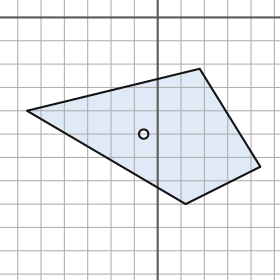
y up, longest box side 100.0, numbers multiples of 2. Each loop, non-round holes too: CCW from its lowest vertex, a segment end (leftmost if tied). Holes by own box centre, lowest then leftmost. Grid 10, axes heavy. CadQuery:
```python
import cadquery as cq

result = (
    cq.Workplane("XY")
    .moveTo(12.0, -80.0)
    .lineTo(44.0, -64.0)
    .lineTo(18.0, -22.0)
    .lineTo(-56.0, -40.0)
    .close()
    .moveTo(-6.0, -50.0)
    .circle(2.0)
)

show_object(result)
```